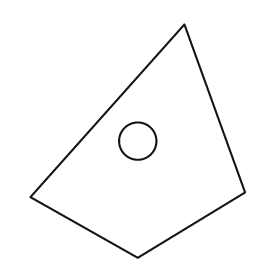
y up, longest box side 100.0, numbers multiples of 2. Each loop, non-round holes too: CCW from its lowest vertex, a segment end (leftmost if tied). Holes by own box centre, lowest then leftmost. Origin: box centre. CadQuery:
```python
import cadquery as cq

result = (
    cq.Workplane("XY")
    .moveTo(0.0, -50.0)
    .lineTo(46.0, -22.0)
    .lineTo(20.0, 50.0)
    .lineTo(-46.0, -24.0)
    .close()
    .moveTo(0.0, 0.0)
    .circle(8.0)
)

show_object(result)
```